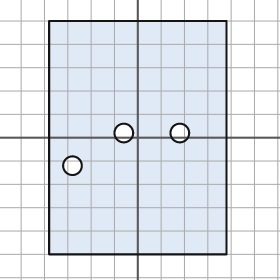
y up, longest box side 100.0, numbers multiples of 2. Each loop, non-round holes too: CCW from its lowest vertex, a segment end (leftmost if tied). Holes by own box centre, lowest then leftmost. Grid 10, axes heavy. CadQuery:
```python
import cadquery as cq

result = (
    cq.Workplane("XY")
    .moveTo(-38.0, -50.0)
    .lineTo(38.0, -50.0)
    .lineTo(38.0, 50.0)
    .lineTo(-38.0, 50.0)
    .close()
    .moveTo(-28.0, -12.0)
    .circle(4.0)
    .moveTo(-6.0, 2.0)
    .circle(4.0)
    .moveTo(18.0, 2.0)
    .circle(4.0)
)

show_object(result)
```